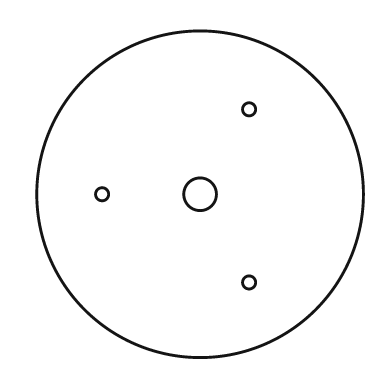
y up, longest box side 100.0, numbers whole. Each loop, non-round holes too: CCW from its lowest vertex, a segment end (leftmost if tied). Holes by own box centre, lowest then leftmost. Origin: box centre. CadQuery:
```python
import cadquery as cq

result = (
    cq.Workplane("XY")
    .moveTo(0.0, 0.0)
    .circle(50.0)
    .moveTo(15.0, -27.0)
    .circle(2.0)
    .moveTo(-30.0, 0.0)
    .circle(2.0)
    .moveTo(0.0, 0.0)
    .circle(5.0)
    .moveTo(15.0, 26.0)
    .circle(2.0)
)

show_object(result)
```